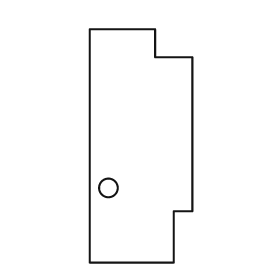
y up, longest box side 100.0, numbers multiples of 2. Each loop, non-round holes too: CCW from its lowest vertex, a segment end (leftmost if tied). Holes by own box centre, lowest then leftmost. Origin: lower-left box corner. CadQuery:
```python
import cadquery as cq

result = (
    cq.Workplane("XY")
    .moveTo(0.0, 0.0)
    .lineTo(36.0, 0.0)
    .lineTo(36.0, 22.0)
    .lineTo(44.0, 22.0)
    .lineTo(44.0, 88.0)
    .lineTo(28.0, 88.0)
    .lineTo(28.0, 100.0)
    .lineTo(0.0, 100.0)
    .close()
    .moveTo(8.0, 32.0)
    .circle(4.0)
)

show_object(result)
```